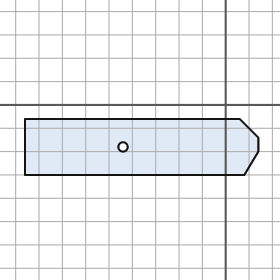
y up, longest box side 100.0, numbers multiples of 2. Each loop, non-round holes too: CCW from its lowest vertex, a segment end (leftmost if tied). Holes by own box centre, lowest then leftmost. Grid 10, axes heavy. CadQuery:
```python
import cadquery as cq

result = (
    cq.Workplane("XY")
    .moveTo(-86.0, -30.0)
    .lineTo(8.0, -30.0)
    .lineTo(14.0, -20.0)
    .lineTo(14.0, -14.0)
    .lineTo(6.0, -6.0)
    .lineTo(-86.0, -6.0)
    .close()
    .moveTo(-44.0, -18.0)
    .circle(2.0)
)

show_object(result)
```